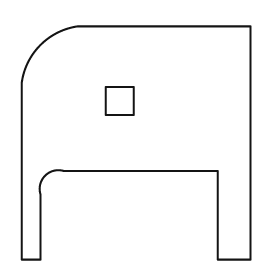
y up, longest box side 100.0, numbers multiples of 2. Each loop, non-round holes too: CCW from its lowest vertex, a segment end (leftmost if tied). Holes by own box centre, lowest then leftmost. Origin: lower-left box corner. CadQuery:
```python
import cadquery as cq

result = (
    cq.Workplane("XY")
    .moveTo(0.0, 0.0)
    .lineTo(8.0, 0.0)
    .lineTo(8.0, 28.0)
    .threePointArc((10.0, 36.0), (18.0, 38.0))
    .lineTo(84.0, 38.0)
    .lineTo(84.0, 0.0)
    .lineTo(98.0, 0.0)
    .lineTo(98.0, 100.0)
    .lineTo(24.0, 100.0)
    .threePointArc((8.0, 92.0), (0.0, 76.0))
    .close()
    .moveTo(36.0, 62.0)
    .lineTo(48.0, 62.0)
    .lineTo(48.0, 74.0)
    .lineTo(36.0, 74.0)
    .close()
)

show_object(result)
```